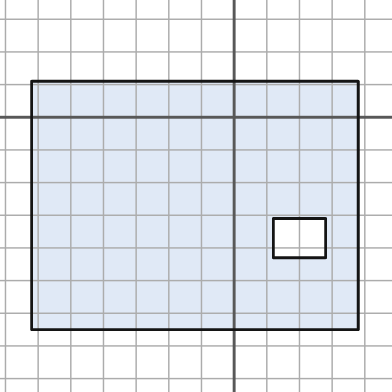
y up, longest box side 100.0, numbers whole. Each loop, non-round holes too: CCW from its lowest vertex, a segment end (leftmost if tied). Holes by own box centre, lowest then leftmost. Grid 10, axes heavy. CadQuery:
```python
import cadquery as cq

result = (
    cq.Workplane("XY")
    .moveTo(-62.0, -65.0)
    .lineTo(38.0, -65.0)
    .lineTo(38.0, 11.0)
    .lineTo(-62.0, 11.0)
    .close()
    .moveTo(12.0, -43.0)
    .lineTo(28.0, -43.0)
    .lineTo(28.0, -31.0)
    .lineTo(12.0, -31.0)
    .close()
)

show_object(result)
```